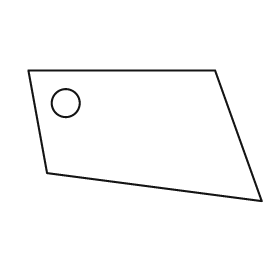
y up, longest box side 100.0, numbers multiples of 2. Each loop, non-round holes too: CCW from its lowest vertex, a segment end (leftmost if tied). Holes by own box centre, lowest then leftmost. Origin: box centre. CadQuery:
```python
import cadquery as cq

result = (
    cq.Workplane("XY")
    .moveTo(50.0, -28.0)
    .lineTo(30.0, 28.0)
    .lineTo(-50.0, 28.0)
    .lineTo(-42.0, -16.0)
    .close()
    .moveTo(-34.0, 14.0)
    .circle(6.0)
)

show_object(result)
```